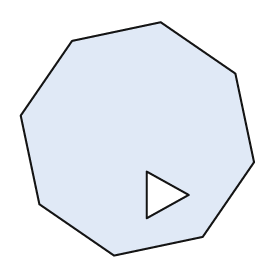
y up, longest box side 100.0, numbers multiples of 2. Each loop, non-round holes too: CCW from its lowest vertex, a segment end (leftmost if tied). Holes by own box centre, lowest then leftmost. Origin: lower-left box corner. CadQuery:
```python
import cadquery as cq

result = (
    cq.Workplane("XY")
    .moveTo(40.0, 0.0)
    .lineTo(78.0, 8.0)
    .lineTo(100.0, 40.0)
    .lineTo(92.0, 78.0)
    .lineTo(60.0, 100.0)
    .lineTo(22.0, 92.0)
    .lineTo(0.0, 60.0)
    .lineTo(8.0, 22.0)
    .close()
    .moveTo(54.0, 16.0)
    .lineTo(72.0, 26.0)
    .lineTo(54.0, 36.0)
    .close()
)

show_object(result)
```